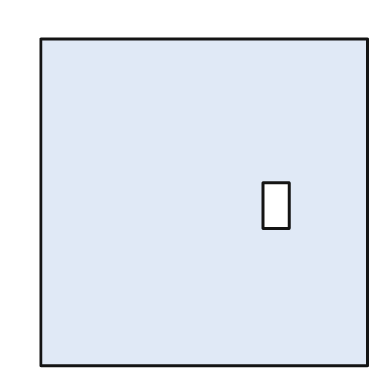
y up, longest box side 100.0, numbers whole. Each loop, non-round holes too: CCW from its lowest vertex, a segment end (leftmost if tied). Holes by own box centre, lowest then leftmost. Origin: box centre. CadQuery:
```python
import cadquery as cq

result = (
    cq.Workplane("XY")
    .moveTo(-50.0, -50.0)
    .lineTo(50.0, -50.0)
    .lineTo(50.0, 50.0)
    .lineTo(-50.0, 50.0)
    .close()
    .moveTo(18.0, -8.0)
    .lineTo(26.0, -8.0)
    .lineTo(26.0, 6.0)
    .lineTo(18.0, 6.0)
    .close()
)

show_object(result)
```